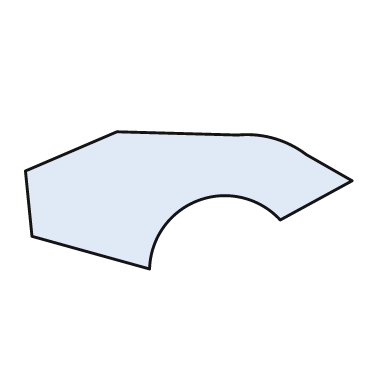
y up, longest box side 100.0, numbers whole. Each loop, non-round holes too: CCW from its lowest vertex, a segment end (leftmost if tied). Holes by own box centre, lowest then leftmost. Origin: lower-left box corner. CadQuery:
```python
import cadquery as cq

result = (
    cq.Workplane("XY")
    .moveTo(38.0, 0.0)
    .threePointArc((53.0, 21.0), (78.0, 15.0))
    .lineTo(100.0, 27.0)
    .lineTo(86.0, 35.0)
    .threePointArc((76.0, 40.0), (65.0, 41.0))
    .lineTo(28.0, 42.0)
    .lineTo(0.0, 30.0)
    .lineTo(2.0, 10.0)
    .close()
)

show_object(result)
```